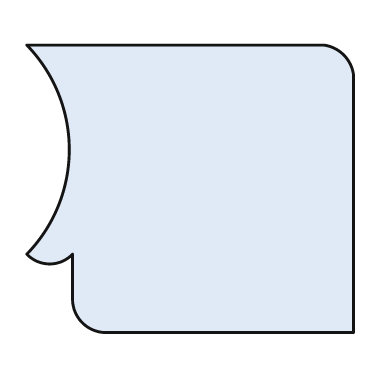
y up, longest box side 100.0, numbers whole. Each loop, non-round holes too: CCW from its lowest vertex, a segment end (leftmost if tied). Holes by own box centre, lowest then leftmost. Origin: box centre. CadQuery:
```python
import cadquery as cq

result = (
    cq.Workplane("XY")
    .moveTo(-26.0, -44.0)
    .lineTo(50.0, -44.0)
    .lineTo(50.0, 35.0)
    .threePointArc((47.0, 41.0), (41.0, 44.0))
    .lineTo(-50.0, 44.0)
    .threePointArc((-37.0, 12.0), (-50.0, -20.0))
    .threePointArc((-43.0, -23.0), (-36.0, -20.0))
    .lineTo(-36.0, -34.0)
    .threePointArc((-33.0, -41.0), (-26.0, -44.0))
    .close()
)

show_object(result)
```